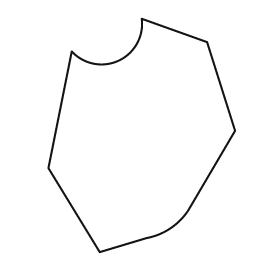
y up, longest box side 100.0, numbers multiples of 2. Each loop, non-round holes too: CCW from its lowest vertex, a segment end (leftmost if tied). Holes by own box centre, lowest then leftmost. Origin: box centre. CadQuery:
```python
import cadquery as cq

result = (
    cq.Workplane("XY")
    .moveTo(-18.0, -50.0)
    .lineTo(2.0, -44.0)
    .threePointArc((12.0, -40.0), (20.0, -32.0))
    .lineTo(40.0, 2.0)
    .lineTo(28.0, 40.0)
    .lineTo(0.0, 50.0)
    .threePointArc((-10.0, 32.0), (-30.0, 36.0))
    .lineTo(-40.0, -14.0)
    .close()
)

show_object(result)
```